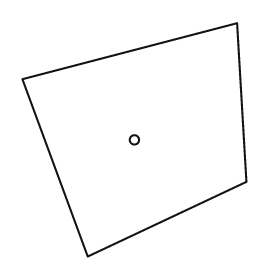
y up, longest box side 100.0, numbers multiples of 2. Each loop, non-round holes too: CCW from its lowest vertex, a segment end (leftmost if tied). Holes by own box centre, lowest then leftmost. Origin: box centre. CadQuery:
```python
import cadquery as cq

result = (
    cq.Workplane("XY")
    .moveTo(-20.0, -50.0)
    .lineTo(48.0, -18.0)
    .lineTo(44.0, 50.0)
    .lineTo(-48.0, 26.0)
    .close()
    .moveTo(0.0, 0.0)
    .circle(2.0)
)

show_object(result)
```